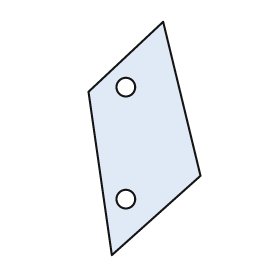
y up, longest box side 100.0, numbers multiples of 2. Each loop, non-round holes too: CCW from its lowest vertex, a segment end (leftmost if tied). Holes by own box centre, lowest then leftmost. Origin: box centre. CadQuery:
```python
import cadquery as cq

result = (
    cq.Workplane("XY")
    .moveTo(-14.0, -50.0)
    .lineTo(24.0, -16.0)
    .lineTo(8.0, 50.0)
    .lineTo(-24.0, 20.0)
    .close()
    .moveTo(-8.0, -26.0)
    .circle(4.0)
    .moveTo(-8.0, 22.0)
    .circle(4.0)
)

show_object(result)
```